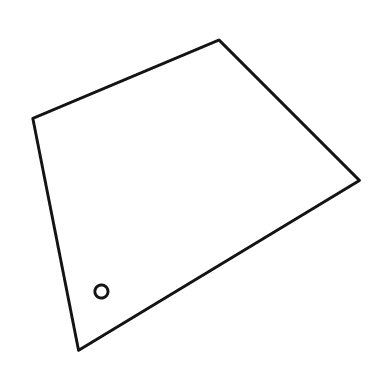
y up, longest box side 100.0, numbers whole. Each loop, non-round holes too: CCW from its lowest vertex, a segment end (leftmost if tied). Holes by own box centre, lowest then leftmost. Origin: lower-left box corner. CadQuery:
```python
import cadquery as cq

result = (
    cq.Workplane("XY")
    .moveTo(14.0, 0.0)
    .lineTo(100.0, 52.0)
    .lineTo(57.0, 95.0)
    .lineTo(0.0, 71.0)
    .close()
    .moveTo(21.0, 18.0)
    .circle(2.0)
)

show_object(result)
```